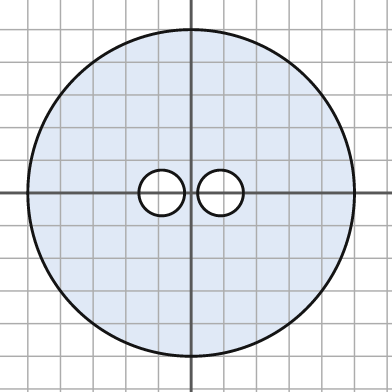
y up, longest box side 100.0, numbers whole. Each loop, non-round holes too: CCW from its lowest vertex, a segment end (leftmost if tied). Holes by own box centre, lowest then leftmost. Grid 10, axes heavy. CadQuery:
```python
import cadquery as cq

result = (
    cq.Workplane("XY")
    .moveTo(0.0, 0.0)
    .circle(50.0)
    .moveTo(-9.0, 0.0)
    .circle(7.0)
    .moveTo(9.0, 0.0)
    .circle(7.0)
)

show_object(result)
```